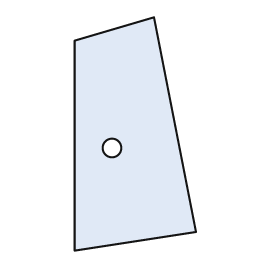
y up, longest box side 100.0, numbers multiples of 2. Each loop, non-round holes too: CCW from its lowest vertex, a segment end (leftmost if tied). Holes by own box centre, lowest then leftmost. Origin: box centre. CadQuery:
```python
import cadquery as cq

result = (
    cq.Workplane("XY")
    .moveTo(-26.0, -50.0)
    .lineTo(26.0, -42.0)
    .lineTo(8.0, 50.0)
    .lineTo(-26.0, 40.0)
    .close()
    .moveTo(-10.0, -6.0)
    .circle(4.0)
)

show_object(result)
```